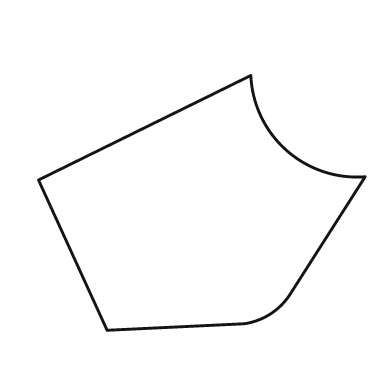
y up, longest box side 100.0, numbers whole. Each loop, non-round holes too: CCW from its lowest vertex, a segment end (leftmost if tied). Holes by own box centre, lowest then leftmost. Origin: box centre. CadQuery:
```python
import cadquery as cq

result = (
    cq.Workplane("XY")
    .moveTo(-29.0, -39.0)
    .lineTo(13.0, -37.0)
    .threePointArc((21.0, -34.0), (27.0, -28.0))
    .lineTo(50.0, 8.0)
    .threePointArc((26.0, 16.0), (15.0, 39.0))
    .lineTo(-50.0, 7.0)
    .close()
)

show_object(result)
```